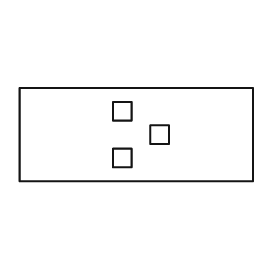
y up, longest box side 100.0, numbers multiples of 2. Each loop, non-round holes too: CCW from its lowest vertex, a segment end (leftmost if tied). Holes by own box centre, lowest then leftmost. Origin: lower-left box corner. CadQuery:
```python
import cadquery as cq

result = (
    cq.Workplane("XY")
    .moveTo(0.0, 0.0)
    .lineTo(100.0, 0.0)
    .lineTo(100.0, 40.0)
    .lineTo(0.0, 40.0)
    .close()
    .moveTo(40.0, 6.0)
    .lineTo(48.0, 6.0)
    .lineTo(48.0, 14.0)
    .lineTo(40.0, 14.0)
    .close()
    .moveTo(56.0, 16.0)
    .lineTo(64.0, 16.0)
    .lineTo(64.0, 24.0)
    .lineTo(56.0, 24.0)
    .close()
    .moveTo(40.0, 26.0)
    .lineTo(48.0, 26.0)
    .lineTo(48.0, 34.0)
    .lineTo(40.0, 34.0)
    .close()
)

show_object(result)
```